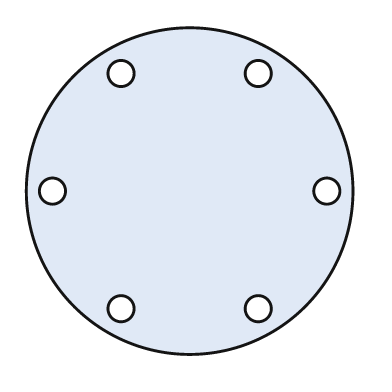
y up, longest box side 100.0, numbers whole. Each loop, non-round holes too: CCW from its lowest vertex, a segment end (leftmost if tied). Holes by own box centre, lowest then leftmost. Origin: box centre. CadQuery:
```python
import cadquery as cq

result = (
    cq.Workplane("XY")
    .moveTo(0.0, 0.0)
    .circle(50.0)
    .moveTo(-21.0, -36.0)
    .circle(4.0)
    .moveTo(21.0, -36.0)
    .circle(4.0)
    .moveTo(-42.0, 0.0)
    .circle(4.0)
    .moveTo(42.0, 0.0)
    .circle(4.0)
    .moveTo(-21.0, 36.0)
    .circle(4.0)
    .moveTo(21.0, 36.0)
    .circle(4.0)
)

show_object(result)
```